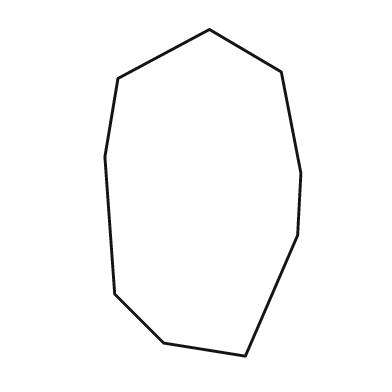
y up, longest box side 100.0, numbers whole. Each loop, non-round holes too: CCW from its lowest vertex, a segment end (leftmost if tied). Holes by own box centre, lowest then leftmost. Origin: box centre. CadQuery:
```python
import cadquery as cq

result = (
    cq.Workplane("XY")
    .moveTo(13.0, -50.0)
    .lineTo(29.0, -13.0)
    .lineTo(30.0, 6.0)
    .lineTo(24.0, 37.0)
    .lineTo(2.0, 50.0)
    .lineTo(-26.0, 35.0)
    .lineTo(-30.0, 11.0)
    .lineTo(-27.0, -31.0)
    .lineTo(-12.0, -46.0)
    .close()
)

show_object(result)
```